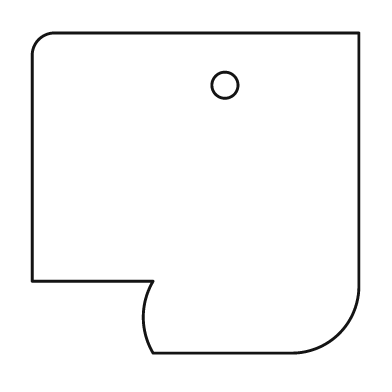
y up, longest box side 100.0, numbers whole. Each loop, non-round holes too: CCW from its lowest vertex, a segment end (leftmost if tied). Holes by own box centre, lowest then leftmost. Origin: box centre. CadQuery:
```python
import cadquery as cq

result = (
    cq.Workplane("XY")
    .moveTo(-13.0, -49.0)
    .lineTo(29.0, -49.0)
    .threePointArc((44.0, -43.0), (50.0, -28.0))
    .lineTo(50.0, 49.0)
    .lineTo(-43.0, 49.0)
    .threePointArc((-48.0, 47.0), (-50.0, 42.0))
    .lineTo(-50.0, -27.0)
    .lineTo(-13.0, -27.0)
    .threePointArc((-16.0, -38.0), (-13.0, -49.0))
    .close()
    .moveTo(9.0, 33.0)
    .circle(4.0)
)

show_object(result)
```